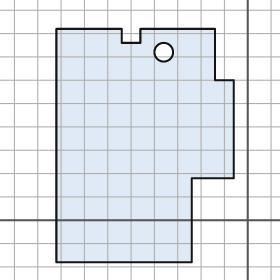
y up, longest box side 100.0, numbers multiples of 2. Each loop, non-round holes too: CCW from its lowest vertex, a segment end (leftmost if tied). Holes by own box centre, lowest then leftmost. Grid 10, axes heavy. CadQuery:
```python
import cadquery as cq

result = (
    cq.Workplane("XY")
    .moveTo(-82.0, -18.0)
    .lineTo(-24.0, -18.0)
    .lineTo(-24.0, 18.0)
    .lineTo(-6.0, 18.0)
    .lineTo(-6.0, 60.0)
    .lineTo(-14.0, 60.0)
    .lineTo(-14.0, 82.0)
    .lineTo(-46.0, 82.0)
    .lineTo(-46.0, 76.0)
    .lineTo(-54.0, 76.0)
    .lineTo(-54.0, 82.0)
    .lineTo(-82.0, 82.0)
    .close()
    .moveTo(-36.0, 72.0)
    .circle(4.0)
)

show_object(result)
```